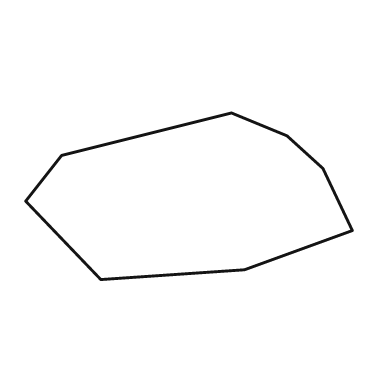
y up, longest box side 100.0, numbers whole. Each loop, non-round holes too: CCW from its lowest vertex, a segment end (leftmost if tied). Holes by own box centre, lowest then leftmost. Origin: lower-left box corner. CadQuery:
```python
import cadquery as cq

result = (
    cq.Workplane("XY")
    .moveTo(23.0, 0.0)
    .lineTo(67.0, 3.0)
    .lineTo(100.0, 15.0)
    .lineTo(91.0, 34.0)
    .lineTo(80.0, 44.0)
    .lineTo(63.0, 51.0)
    .lineTo(11.0, 38.0)
    .lineTo(0.0, 24.0)
    .close()
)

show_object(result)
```